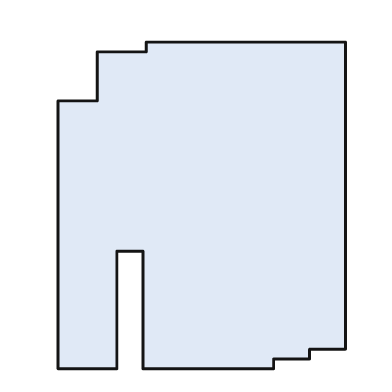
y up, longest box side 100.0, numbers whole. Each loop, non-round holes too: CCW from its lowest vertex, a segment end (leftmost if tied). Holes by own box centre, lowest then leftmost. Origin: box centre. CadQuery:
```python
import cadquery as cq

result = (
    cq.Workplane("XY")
    .moveTo(-44.0, -50.0)
    .lineTo(-26.0, -50.0)
    .lineTo(-26.0, -14.0)
    .lineTo(-18.0, -14.0)
    .lineTo(-18.0, -50.0)
    .lineTo(22.0, -50.0)
    .lineTo(22.0, -47.0)
    .lineTo(33.0, -47.0)
    .lineTo(33.0, -44.0)
    .lineTo(44.0, -44.0)
    .lineTo(44.0, 50.0)
    .lineTo(-17.0, 50.0)
    .lineTo(-17.0, 47.0)
    .lineTo(-32.0, 47.0)
    .lineTo(-32.0, 32.0)
    .lineTo(-44.0, 32.0)
    .close()
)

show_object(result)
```